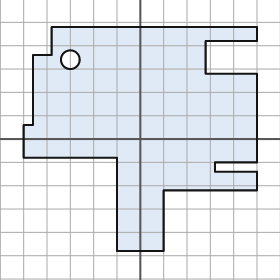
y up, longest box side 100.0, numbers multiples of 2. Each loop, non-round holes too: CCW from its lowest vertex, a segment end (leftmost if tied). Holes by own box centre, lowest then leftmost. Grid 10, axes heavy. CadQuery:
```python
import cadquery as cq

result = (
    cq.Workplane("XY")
    .moveTo(-10.0, -48.0)
    .lineTo(10.0, -48.0)
    .lineTo(10.0, -22.0)
    .lineTo(50.0, -22.0)
    .lineTo(50.0, -14.0)
    .lineTo(32.0, -14.0)
    .lineTo(32.0, -10.0)
    .lineTo(50.0, -10.0)
    .lineTo(50.0, 28.0)
    .lineTo(28.0, 28.0)
    .lineTo(28.0, 42.0)
    .lineTo(50.0, 42.0)
    .lineTo(50.0, 48.0)
    .lineTo(-38.0, 48.0)
    .lineTo(-38.0, 36.0)
    .lineTo(-46.0, 36.0)
    .lineTo(-46.0, 6.0)
    .lineTo(-50.0, 6.0)
    .lineTo(-50.0, -8.0)
    .lineTo(-10.0, -8.0)
    .close()
    .moveTo(-30.0, 34.0)
    .circle(4.0)
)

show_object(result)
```